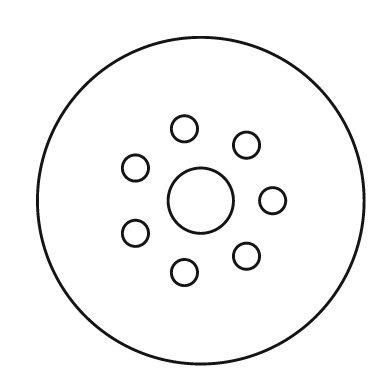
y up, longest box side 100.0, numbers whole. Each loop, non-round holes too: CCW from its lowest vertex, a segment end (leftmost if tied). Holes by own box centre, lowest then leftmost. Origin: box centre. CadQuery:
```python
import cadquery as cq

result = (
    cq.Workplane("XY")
    .moveTo(0.0, 0.0)
    .circle(50.0)
    .moveTo(-5.0, -22.0)
    .circle(4.0)
    .moveTo(14.0, -17.0)
    .circle(4.0)
    .moveTo(-20.0, -10.0)
    .circle(4.0)
    .moveTo(0.0, 0.0)
    .circle(10.0)
    .moveTo(22.0, 0.0)
    .circle(4.0)
    .moveTo(-20.0, 10.0)
    .circle(4.0)
    .moveTo(14.0, 17.0)
    .circle(4.0)
    .moveTo(-5.0, 22.0)
    .circle(4.0)
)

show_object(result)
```